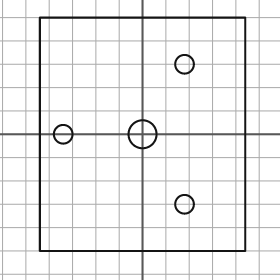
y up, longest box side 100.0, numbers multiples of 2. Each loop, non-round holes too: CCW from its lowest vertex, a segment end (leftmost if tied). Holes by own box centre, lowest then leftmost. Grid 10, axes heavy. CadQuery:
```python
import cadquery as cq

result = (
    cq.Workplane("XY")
    .moveTo(-44.0, -50.0)
    .lineTo(44.0, -50.0)
    .lineTo(44.0, 50.0)
    .lineTo(-44.0, 50.0)
    .close()
    .moveTo(18.0, -30.0)
    .circle(4.0)
    .moveTo(-34.0, 0.0)
    .circle(4.0)
    .moveTo(0.0, 0.0)
    .circle(6.0)
    .moveTo(18.0, 30.0)
    .circle(4.0)
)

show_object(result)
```